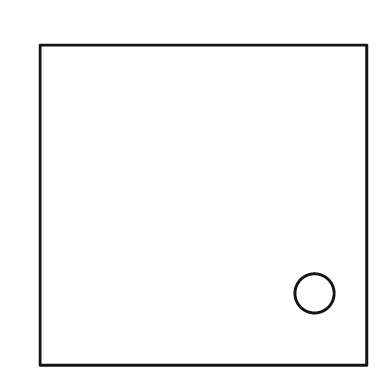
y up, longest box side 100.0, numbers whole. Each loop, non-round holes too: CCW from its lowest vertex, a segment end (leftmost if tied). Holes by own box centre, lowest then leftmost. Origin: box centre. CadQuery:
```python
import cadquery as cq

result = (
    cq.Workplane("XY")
    .moveTo(-50.0, -49.0)
    .lineTo(50.0, -49.0)
    .lineTo(50.0, 49.0)
    .lineTo(-50.0, 49.0)
    .close()
    .moveTo(34.0, -27.0)
    .circle(6.0)
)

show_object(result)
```